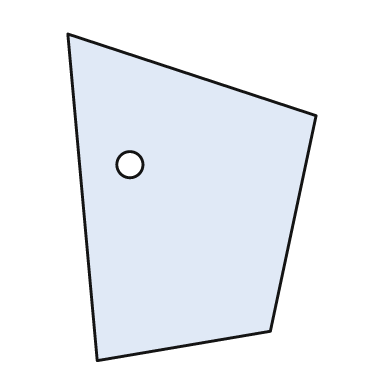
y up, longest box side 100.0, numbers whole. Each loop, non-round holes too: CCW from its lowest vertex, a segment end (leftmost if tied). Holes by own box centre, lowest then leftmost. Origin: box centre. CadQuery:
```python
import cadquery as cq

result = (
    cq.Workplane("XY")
    .moveTo(-29.0, -50.0)
    .lineTo(24.0, -41.0)
    .lineTo(38.0, 25.0)
    .lineTo(-38.0, 50.0)
    .close()
    .moveTo(-19.0, 10.0)
    .circle(4.0)
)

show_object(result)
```